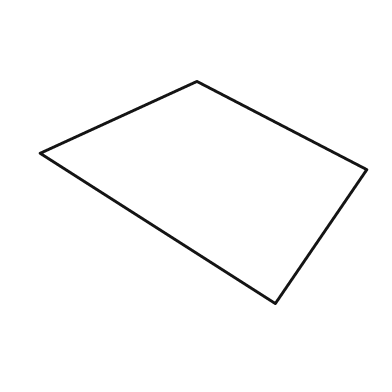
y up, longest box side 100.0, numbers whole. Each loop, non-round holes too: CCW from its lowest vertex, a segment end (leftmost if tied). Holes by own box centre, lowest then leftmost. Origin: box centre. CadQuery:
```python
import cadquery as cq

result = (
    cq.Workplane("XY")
    .moveTo(22.0, -34.0)
    .lineTo(50.0, 7.0)
    .lineTo(-2.0, 34.0)
    .lineTo(-50.0, 12.0)
    .close()
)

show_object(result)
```